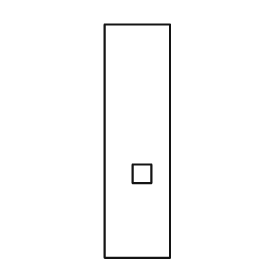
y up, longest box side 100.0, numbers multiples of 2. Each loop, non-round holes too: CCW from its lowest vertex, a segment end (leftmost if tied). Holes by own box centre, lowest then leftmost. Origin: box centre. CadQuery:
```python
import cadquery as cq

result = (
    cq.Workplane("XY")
    .moveTo(-14.0, -50.0)
    .lineTo(14.0, -50.0)
    .lineTo(14.0, 50.0)
    .lineTo(-14.0, 50.0)
    .close()
    .moveTo(-2.0, -18.0)
    .lineTo(6.0, -18.0)
    .lineTo(6.0, -10.0)
    .lineTo(-2.0, -10.0)
    .close()
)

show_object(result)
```